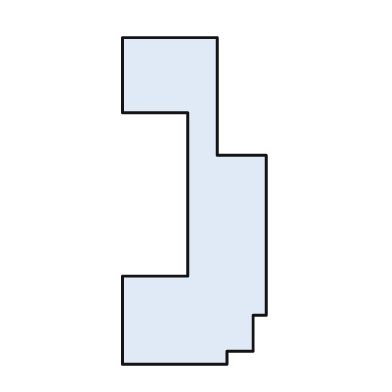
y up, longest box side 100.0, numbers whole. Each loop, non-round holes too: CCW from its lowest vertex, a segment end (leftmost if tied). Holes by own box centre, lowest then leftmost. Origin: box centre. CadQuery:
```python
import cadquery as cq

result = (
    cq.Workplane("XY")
    .moveTo(-22.0, -50.0)
    .lineTo(10.0, -50.0)
    .lineTo(10.0, -46.0)
    .lineTo(18.0, -46.0)
    .lineTo(18.0, -35.0)
    .lineTo(22.0, -35.0)
    .lineTo(22.0, 14.0)
    .lineTo(7.0, 14.0)
    .lineTo(7.0, 50.0)
    .lineTo(-22.0, 50.0)
    .lineTo(-22.0, 27.0)
    .lineTo(-2.0, 27.0)
    .lineTo(-2.0, -23.0)
    .lineTo(-22.0, -23.0)
    .close()
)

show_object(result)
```